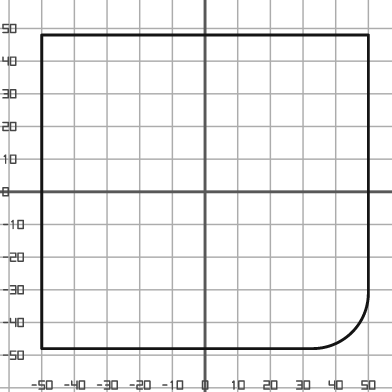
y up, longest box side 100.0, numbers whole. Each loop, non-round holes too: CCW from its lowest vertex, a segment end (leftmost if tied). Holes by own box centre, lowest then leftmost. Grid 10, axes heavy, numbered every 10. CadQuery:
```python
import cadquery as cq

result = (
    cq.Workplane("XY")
    .moveTo(-50.0, -48.0)
    .lineTo(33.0, -48.0)
    .threePointArc((45.0, -43.0), (50.0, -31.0))
    .lineTo(50.0, 48.0)
    .lineTo(-50.0, 48.0)
    .close()
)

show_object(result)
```